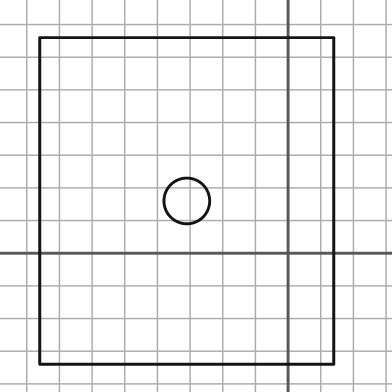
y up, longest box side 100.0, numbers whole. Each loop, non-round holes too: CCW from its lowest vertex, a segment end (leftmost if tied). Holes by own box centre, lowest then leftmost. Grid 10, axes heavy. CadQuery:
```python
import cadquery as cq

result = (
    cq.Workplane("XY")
    .moveTo(-76.0, -34.0)
    .lineTo(14.0, -34.0)
    .lineTo(14.0, 66.0)
    .lineTo(-76.0, 66.0)
    .close()
    .moveTo(-31.0, 16.0)
    .circle(7.0)
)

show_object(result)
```